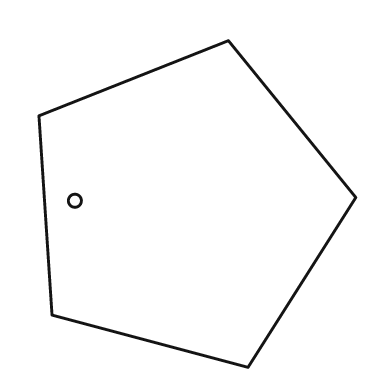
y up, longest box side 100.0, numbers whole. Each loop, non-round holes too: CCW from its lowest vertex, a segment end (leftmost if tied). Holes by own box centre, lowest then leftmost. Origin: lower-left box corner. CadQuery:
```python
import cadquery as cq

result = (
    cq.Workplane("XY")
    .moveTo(64.0, 0.0)
    .lineTo(97.0, 52.0)
    .lineTo(58.0, 100.0)
    .lineTo(0.0, 77.0)
    .lineTo(4.0, 16.0)
    .close()
    .moveTo(11.0, 51.0)
    .circle(2.0)
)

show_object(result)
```